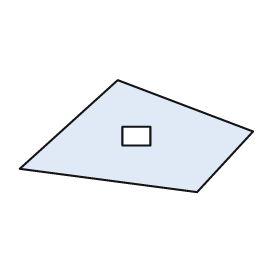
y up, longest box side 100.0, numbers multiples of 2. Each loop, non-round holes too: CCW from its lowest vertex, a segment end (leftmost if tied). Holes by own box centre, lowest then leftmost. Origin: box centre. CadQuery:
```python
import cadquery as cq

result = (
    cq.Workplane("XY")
    .moveTo(26.0, -24.0)
    .lineTo(50.0, 2.0)
    .lineTo(-8.0, 24.0)
    .lineTo(-50.0, -14.0)
    .close()
    .moveTo(-6.0, -4.0)
    .lineTo(6.0, -4.0)
    .lineTo(6.0, 4.0)
    .lineTo(-6.0, 4.0)
    .close()
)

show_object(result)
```